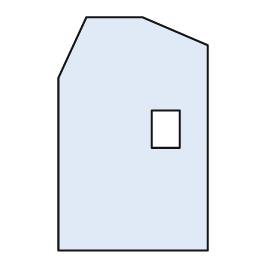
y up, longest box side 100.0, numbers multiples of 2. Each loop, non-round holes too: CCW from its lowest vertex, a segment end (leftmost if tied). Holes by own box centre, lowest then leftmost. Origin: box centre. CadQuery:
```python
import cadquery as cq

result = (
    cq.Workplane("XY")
    .moveTo(-32.0, -50.0)
    .lineTo(32.0, -50.0)
    .lineTo(32.0, 38.0)
    .lineTo(4.0, 50.0)
    .lineTo(-20.0, 50.0)
    .lineTo(-32.0, 24.0)
    .close()
    .moveTo(8.0, -6.0)
    .lineTo(20.0, -6.0)
    .lineTo(20.0, 10.0)
    .lineTo(8.0, 10.0)
    .close()
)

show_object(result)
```